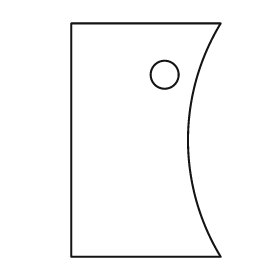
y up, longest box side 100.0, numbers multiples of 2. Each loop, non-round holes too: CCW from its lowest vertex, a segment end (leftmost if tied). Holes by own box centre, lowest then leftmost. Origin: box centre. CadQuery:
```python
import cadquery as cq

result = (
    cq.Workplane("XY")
    .moveTo(-32.0, -50.0)
    .lineTo(32.0, -50.0)
    .threePointArc((18.0, 0.0), (32.0, 50.0))
    .lineTo(-32.0, 50.0)
    .close()
    .moveTo(8.0, 28.0)
    .circle(6.0)
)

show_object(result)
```